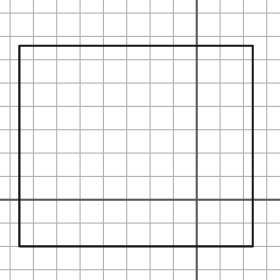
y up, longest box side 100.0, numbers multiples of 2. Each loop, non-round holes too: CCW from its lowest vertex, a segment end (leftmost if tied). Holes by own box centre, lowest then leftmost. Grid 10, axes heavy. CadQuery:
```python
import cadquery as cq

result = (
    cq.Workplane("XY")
    .moveTo(-76.0, -20.0)
    .lineTo(24.0, -20.0)
    .lineTo(24.0, 66.0)
    .lineTo(-76.0, 66.0)
    .close()
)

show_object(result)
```